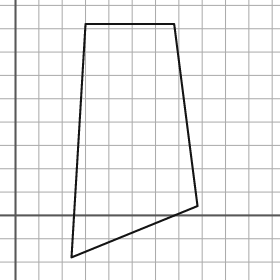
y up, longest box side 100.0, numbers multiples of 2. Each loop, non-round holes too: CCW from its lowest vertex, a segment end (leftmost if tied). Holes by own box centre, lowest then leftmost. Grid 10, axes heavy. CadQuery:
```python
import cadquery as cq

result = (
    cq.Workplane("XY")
    .moveTo(24.0, -18.0)
    .lineTo(78.0, 4.0)
    .lineTo(68.0, 82.0)
    .lineTo(30.0, 82.0)
    .close()
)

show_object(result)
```